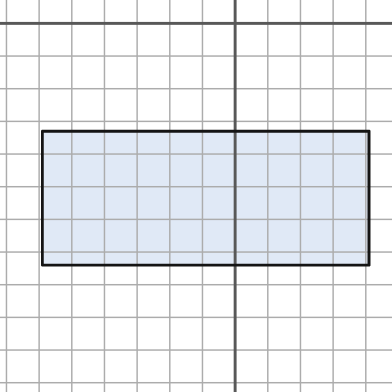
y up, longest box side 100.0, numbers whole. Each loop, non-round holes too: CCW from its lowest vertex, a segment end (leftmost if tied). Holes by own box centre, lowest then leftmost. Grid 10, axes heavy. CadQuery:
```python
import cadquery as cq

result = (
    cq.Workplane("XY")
    .moveTo(-59.0, -74.0)
    .lineTo(41.0, -74.0)
    .lineTo(41.0, -33.0)
    .lineTo(-59.0, -33.0)
    .close()
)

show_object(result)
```